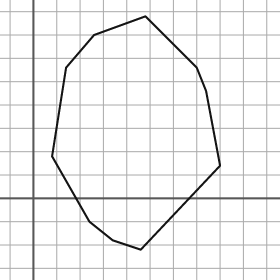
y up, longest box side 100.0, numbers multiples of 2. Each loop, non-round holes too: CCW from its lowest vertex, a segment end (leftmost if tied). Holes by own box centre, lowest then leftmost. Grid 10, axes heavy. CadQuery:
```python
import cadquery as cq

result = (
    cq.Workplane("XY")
    .moveTo(46.0, -22.0)
    .lineTo(80.0, 14.0)
    .lineTo(74.0, 46.0)
    .lineTo(70.0, 56.0)
    .lineTo(48.0, 78.0)
    .lineTo(26.0, 70.0)
    .lineTo(14.0, 56.0)
    .lineTo(8.0, 18.0)
    .lineTo(24.0, -10.0)
    .lineTo(34.0, -18.0)
    .close()
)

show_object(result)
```